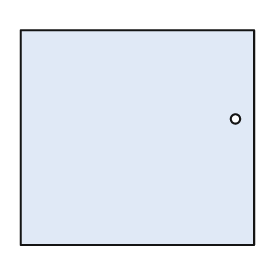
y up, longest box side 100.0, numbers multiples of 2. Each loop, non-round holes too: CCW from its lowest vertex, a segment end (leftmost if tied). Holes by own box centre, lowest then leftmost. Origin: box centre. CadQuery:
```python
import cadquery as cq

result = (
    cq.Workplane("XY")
    .moveTo(-50.0, -46.0)
    .lineTo(50.0, -46.0)
    .lineTo(50.0, 46.0)
    .lineTo(-50.0, 46.0)
    .close()
    .moveTo(42.0, 8.0)
    .circle(2.0)
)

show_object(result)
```